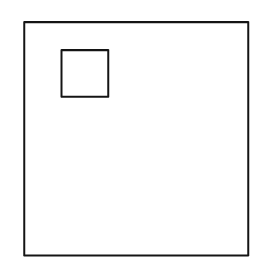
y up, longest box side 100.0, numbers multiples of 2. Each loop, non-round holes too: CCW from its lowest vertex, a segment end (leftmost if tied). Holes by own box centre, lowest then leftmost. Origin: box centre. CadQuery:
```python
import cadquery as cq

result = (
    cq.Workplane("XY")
    .moveTo(-48.0, -50.0)
    .lineTo(48.0, -50.0)
    .lineTo(48.0, 50.0)
    .lineTo(-48.0, 50.0)
    .close()
    .moveTo(-32.0, 18.0)
    .lineTo(-12.0, 18.0)
    .lineTo(-12.0, 38.0)
    .lineTo(-32.0, 38.0)
    .close()
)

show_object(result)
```